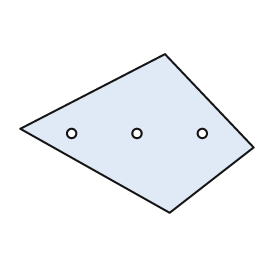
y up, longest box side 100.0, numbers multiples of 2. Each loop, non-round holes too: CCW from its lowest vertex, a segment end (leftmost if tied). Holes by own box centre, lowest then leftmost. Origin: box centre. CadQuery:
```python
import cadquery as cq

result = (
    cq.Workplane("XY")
    .moveTo(14.0, -34.0)
    .lineTo(50.0, -6.0)
    .lineTo(12.0, 34.0)
    .lineTo(-50.0, 2.0)
    .close()
    .moveTo(-28.0, 0.0)
    .circle(2.0)
    .moveTo(0.0, 0.0)
    .circle(2.0)
    .moveTo(28.0, 0.0)
    .circle(2.0)
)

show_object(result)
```